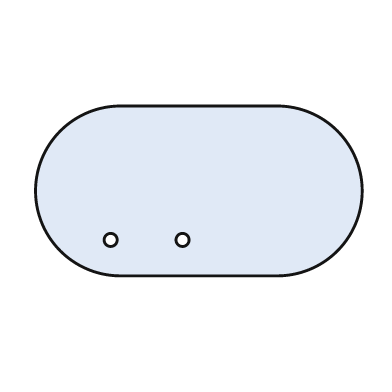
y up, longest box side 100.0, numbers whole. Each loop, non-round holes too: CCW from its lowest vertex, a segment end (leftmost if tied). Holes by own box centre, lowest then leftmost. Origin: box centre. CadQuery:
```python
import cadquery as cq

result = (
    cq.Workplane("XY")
    .moveTo(-24.0, -26.0)
    .lineTo(24.0, -26.0)
    .threePointArc((50.0, 0.0), (24.0, 26.0))
    .lineTo(-24.0, 26.0)
    .threePointArc((-50.0, 0.0), (-24.0, -26.0))
    .close()
    .moveTo(-27.0, -15.0)
    .circle(2.0)
    .moveTo(-5.0, -15.0)
    .circle(2.0)
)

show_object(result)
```